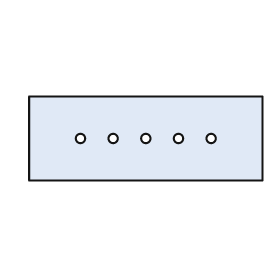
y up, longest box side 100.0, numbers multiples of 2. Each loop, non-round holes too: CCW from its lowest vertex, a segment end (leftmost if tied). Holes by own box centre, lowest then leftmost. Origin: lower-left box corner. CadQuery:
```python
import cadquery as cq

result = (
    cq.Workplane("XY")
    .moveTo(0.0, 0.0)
    .lineTo(100.0, 0.0)
    .lineTo(100.0, 36.0)
    .lineTo(0.0, 36.0)
    .close()
    .moveTo(22.0, 18.0)
    .circle(2.0)
    .moveTo(36.0, 18.0)
    .circle(2.0)
    .moveTo(50.0, 18.0)
    .circle(2.0)
    .moveTo(64.0, 18.0)
    .circle(2.0)
    .moveTo(78.0, 18.0)
    .circle(2.0)
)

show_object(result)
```